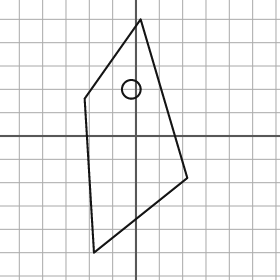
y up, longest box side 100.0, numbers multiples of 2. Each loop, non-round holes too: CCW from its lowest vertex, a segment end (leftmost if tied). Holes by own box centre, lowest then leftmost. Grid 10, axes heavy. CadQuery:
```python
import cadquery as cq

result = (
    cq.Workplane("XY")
    .moveTo(-18.0, -50.0)
    .lineTo(22.0, -18.0)
    .lineTo(2.0, 50.0)
    .lineTo(-22.0, 16.0)
    .close()
    .moveTo(-2.0, 20.0)
    .circle(4.0)
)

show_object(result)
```